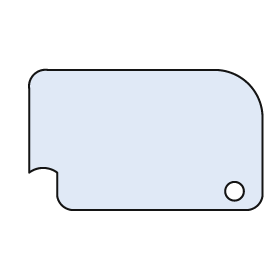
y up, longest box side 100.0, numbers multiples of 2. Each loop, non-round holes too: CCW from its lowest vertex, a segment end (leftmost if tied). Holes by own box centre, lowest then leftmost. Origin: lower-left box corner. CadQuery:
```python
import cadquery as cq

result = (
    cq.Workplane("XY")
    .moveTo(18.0, 0.0)
    .lineTo(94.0, 0.0)
    .threePointArc((98.0, 2.0), (100.0, 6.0))
    .lineTo(100.0, 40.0)
    .threePointArc((94.0, 54.0), (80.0, 60.0))
    .lineTo(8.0, 60.0)
    .threePointArc((2.0, 58.0), (0.0, 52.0))
    .lineTo(0.0, 16.0)
    .threePointArc((6.0, 18.0), (12.0, 16.0))
    .lineTo(12.0, 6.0)
    .threePointArc((14.0, 2.0), (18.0, 0.0))
    .close()
    .moveTo(88.0, 8.0)
    .circle(4.0)
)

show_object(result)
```